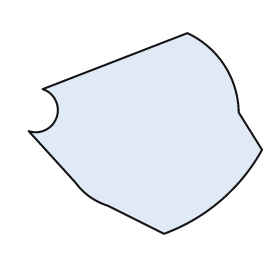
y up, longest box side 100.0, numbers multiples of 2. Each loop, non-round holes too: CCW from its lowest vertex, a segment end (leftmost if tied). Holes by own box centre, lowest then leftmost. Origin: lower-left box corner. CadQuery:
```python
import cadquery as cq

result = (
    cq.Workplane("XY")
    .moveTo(58.0, 0.0)
    .threePointArc((82.0, 14.0), (100.0, 36.0))
    .lineTo(90.0, 52.0)
    .threePointArc((84.0, 72.0), (68.0, 86.0))
    .lineTo(6.0, 62.0)
    .threePointArc((12.0, 50.0), (0.0, 44.0))
    .lineTo(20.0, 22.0)
    .threePointArc((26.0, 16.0), (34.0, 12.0))
    .close()
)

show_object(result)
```